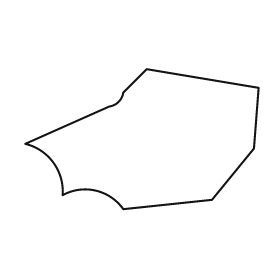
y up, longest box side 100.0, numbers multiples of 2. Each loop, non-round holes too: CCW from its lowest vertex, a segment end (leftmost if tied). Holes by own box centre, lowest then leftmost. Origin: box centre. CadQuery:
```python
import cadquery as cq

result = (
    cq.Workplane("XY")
    .moveTo(-8.0, -30.0)
    .lineTo(30.0, -26.0)
    .lineTo(48.0, -4.0)
    .lineTo(50.0, 22.0)
    .lineTo(2.0, 30.0)
    .lineTo(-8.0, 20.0)
    .threePointArc((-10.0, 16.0), (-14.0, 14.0))
    .lineTo(-50.0, -2.0)
    .threePointArc((-38.0, -10.0), (-34.0, -24.0))
    .threePointArc((-20.0, -22.0), (-8.0, -30.0))
    .close()
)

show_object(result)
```